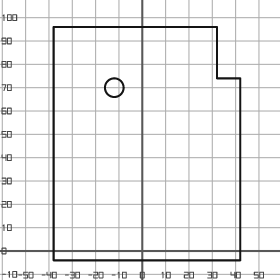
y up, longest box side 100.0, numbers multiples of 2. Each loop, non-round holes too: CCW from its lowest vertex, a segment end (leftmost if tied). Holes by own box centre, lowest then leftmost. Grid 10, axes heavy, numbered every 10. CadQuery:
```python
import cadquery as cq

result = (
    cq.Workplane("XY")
    .moveTo(-38.0, -4.0)
    .lineTo(42.0, -4.0)
    .lineTo(42.0, 74.0)
    .lineTo(32.0, 74.0)
    .lineTo(32.0, 96.0)
    .lineTo(-38.0, 96.0)
    .close()
    .moveTo(-12.0, 70.0)
    .circle(4.0)
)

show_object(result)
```